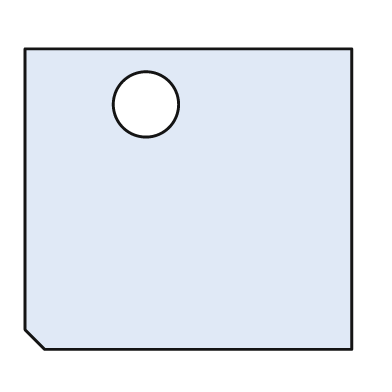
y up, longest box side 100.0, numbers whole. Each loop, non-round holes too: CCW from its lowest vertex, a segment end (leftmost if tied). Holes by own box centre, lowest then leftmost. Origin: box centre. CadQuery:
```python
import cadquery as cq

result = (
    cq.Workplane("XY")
    .moveTo(-44.0, -46.0)
    .lineTo(50.0, -46.0)
    .lineTo(50.0, 46.0)
    .lineTo(-50.0, 46.0)
    .lineTo(-50.0, -40.0)
    .close()
    .moveTo(-13.0, 29.0)
    .circle(10.0)
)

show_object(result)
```